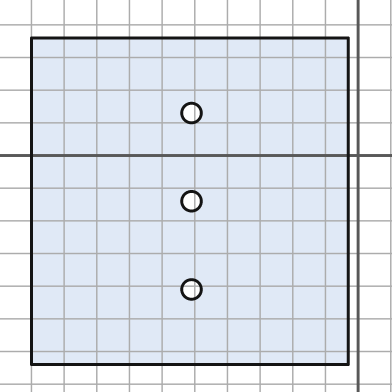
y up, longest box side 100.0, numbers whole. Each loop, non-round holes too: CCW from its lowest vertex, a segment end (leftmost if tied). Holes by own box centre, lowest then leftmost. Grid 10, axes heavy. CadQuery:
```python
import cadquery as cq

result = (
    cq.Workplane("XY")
    .moveTo(-100.0, -64.0)
    .lineTo(-3.0, -64.0)
    .lineTo(-3.0, 36.0)
    .lineTo(-100.0, 36.0)
    .close()
    .moveTo(-51.0, -41.0)
    .circle(3.0)
    .moveTo(-51.0, -14.0)
    .circle(3.0)
    .moveTo(-51.0, 13.0)
    .circle(3.0)
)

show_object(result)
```